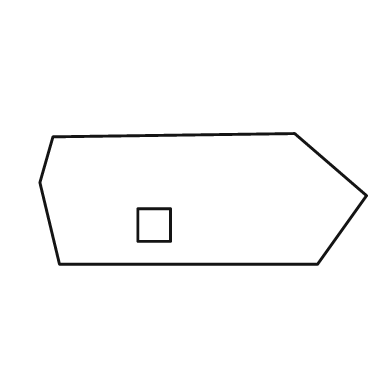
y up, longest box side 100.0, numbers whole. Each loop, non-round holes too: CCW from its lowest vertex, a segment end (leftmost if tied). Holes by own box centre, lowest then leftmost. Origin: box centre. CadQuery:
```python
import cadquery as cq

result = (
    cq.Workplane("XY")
    .moveTo(-44.0, -20.0)
    .lineTo(35.0, -20.0)
    .lineTo(50.0, 1.0)
    .lineTo(28.0, 20.0)
    .lineTo(-46.0, 19.0)
    .lineTo(-50.0, 5.0)
    .close()
    .moveTo(-20.0, -13.0)
    .lineTo(-10.0, -13.0)
    .lineTo(-10.0, -3.0)
    .lineTo(-20.0, -3.0)
    .close()
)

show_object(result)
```